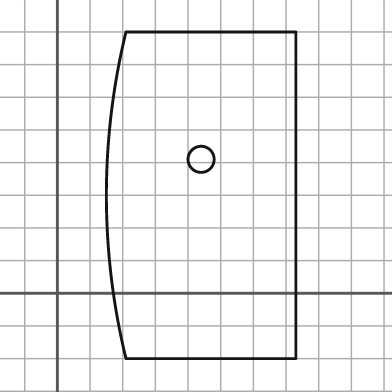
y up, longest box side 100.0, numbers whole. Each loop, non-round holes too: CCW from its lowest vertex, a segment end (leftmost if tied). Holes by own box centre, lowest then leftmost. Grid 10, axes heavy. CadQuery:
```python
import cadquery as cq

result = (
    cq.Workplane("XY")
    .moveTo(21.0, -20.0)
    .lineTo(73.0, -20.0)
    .lineTo(73.0, 80.0)
    .lineTo(21.0, 80.0)
    .threePointArc((15.0, 30.0), (21.0, -20.0))
    .close()
    .moveTo(44.0, 41.0)
    .circle(4.0)
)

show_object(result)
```